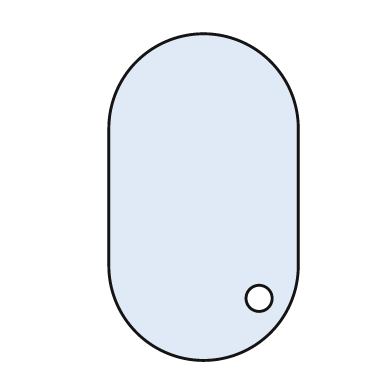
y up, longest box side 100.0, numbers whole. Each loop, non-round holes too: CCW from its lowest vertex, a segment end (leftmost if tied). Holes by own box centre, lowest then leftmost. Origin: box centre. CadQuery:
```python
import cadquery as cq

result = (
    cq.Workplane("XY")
    .moveTo(-29.0, -21.0)
    .threePointArc((0.0, -50.0), (29.0, -21.0))
    .lineTo(29.0, 21.0)
    .threePointArc((0.0, 50.0), (-29.0, 21.0))
    .close()
    .moveTo(17.0, -31.0)
    .circle(4.0)
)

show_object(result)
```